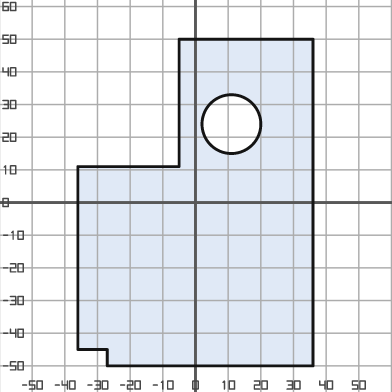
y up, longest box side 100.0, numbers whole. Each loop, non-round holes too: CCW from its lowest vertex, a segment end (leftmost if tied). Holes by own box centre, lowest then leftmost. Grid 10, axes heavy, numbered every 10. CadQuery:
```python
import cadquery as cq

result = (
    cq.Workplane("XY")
    .moveTo(-27.0, -50.0)
    .lineTo(36.0, -50.0)
    .lineTo(36.0, 50.0)
    .lineTo(-5.0, 50.0)
    .lineTo(-5.0, 11.0)
    .lineTo(-36.0, 11.0)
    .lineTo(-36.0, -45.0)
    .lineTo(-27.0, -45.0)
    .close()
    .moveTo(11.0, 24.0)
    .circle(9.0)
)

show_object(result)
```